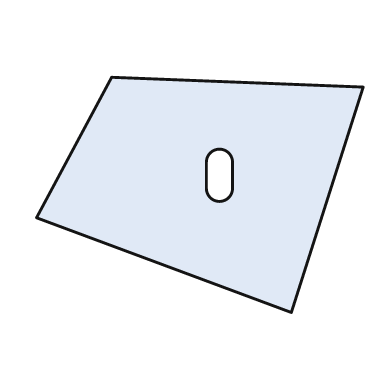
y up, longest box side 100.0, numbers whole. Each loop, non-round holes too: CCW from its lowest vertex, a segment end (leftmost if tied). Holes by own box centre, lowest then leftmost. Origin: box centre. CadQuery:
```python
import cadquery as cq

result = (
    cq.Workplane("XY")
    .moveTo(28.0, -36.0)
    .lineTo(50.0, 33.0)
    .lineTo(-27.0, 36.0)
    .lineTo(-50.0, -7.0)
    .close()
    .moveTo(2.0, 2.0)
    .threePointArc((6.0, -2.0), (10.0, 2.0))
    .lineTo(10.0, 10.0)
    .threePointArc((6.0, 14.0), (2.0, 10.0))
    .close()
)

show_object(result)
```